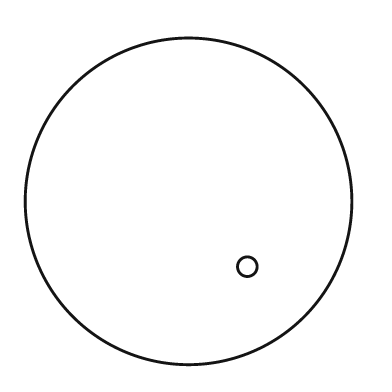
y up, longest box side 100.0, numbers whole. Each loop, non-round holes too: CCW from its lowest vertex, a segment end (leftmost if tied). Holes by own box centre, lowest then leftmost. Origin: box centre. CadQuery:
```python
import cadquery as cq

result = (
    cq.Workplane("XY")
    .moveTo(0.0, 0.0)
    .circle(50.0)
    .moveTo(18.0, -20.0)
    .circle(3.0)
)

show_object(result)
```